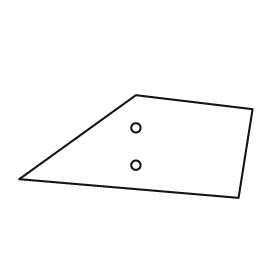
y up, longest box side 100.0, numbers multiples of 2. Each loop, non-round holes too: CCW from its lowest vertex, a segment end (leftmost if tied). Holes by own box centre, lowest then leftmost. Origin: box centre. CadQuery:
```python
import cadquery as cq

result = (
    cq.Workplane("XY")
    .moveTo(44.0, -22.0)
    .lineTo(50.0, 16.0)
    .lineTo(0.0, 22.0)
    .lineTo(-50.0, -14.0)
    .close()
    .moveTo(0.0, -8.0)
    .circle(2.0)
    .moveTo(0.0, 8.0)
    .circle(2.0)
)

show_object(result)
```